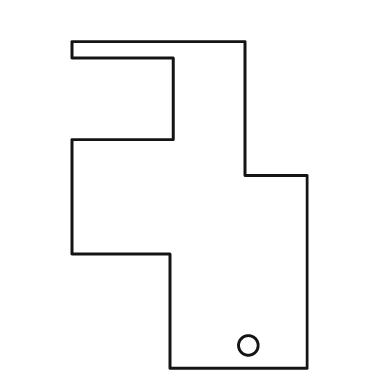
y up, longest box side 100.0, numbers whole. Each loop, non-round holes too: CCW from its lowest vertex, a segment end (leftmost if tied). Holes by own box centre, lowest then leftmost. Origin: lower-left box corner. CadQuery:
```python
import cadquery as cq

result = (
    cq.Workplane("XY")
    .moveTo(30.0, 0.0)
    .lineTo(72.0, 0.0)
    .lineTo(72.0, 59.0)
    .lineTo(53.0, 59.0)
    .lineTo(53.0, 100.0)
    .lineTo(0.0, 100.0)
    .lineTo(0.0, 95.0)
    .lineTo(31.0, 95.0)
    .lineTo(31.0, 70.0)
    .lineTo(0.0, 70.0)
    .lineTo(0.0, 35.0)
    .lineTo(30.0, 35.0)
    .close()
    .moveTo(54.0, 7.0)
    .circle(3.0)
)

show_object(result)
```